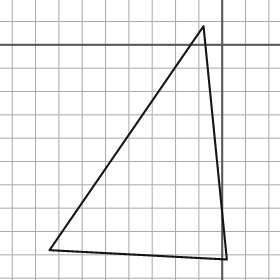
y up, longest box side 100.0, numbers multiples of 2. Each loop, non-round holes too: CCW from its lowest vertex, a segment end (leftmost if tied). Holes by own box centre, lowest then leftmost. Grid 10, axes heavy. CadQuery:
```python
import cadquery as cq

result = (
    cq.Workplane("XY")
    .moveTo(2.0, -92.0)
    .lineTo(-8.0, 8.0)
    .lineTo(-74.0, -88.0)
    .close()
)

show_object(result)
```